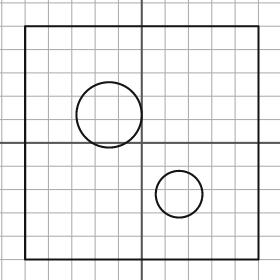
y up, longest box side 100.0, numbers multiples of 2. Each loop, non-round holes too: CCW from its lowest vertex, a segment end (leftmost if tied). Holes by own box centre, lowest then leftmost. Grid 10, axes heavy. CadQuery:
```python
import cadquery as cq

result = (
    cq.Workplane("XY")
    .moveTo(-50.0, -50.0)
    .lineTo(50.0, -50.0)
    .lineTo(50.0, 50.0)
    .lineTo(-50.0, 50.0)
    .close()
    .moveTo(16.0, -22.0)
    .circle(10.0)
    .moveTo(-14.0, 12.0)
    .circle(14.0)
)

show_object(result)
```